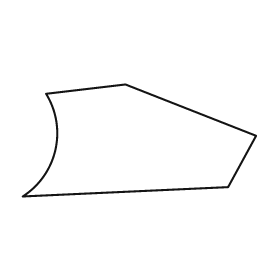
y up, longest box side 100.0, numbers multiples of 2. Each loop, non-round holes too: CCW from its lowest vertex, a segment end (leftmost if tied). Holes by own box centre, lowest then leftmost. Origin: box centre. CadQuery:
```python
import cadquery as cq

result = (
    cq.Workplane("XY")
    .moveTo(-50.0, -24.0)
    .lineTo(38.0, -20.0)
    .lineTo(50.0, 2.0)
    .lineTo(-6.0, 24.0)
    .lineTo(-40.0, 20.0)
    .threePointArc((-36.0, -4.0), (-50.0, -24.0))
    .close()
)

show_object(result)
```